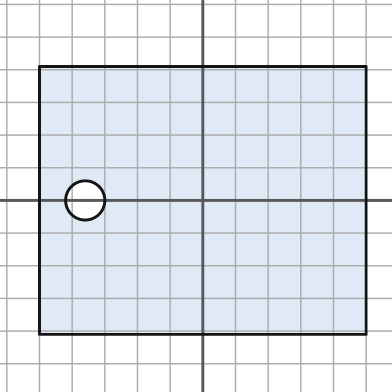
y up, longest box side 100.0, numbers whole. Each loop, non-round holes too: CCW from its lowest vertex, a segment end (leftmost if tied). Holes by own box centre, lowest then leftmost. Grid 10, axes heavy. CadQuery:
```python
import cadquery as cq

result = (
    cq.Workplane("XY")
    .moveTo(-50.0, -41.0)
    .lineTo(50.0, -41.0)
    .lineTo(50.0, 41.0)
    .lineTo(-50.0, 41.0)
    .close()
    .moveTo(-36.0, 0.0)
    .circle(6.0)
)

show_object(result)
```